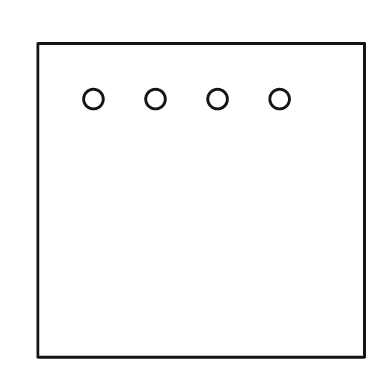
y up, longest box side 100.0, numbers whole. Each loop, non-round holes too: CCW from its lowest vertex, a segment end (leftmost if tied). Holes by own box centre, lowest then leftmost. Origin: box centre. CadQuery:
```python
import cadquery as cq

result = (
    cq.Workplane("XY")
    .moveTo(-50.0, -48.0)
    .lineTo(50.0, -48.0)
    .lineTo(50.0, 48.0)
    .lineTo(-50.0, 48.0)
    .close()
    .moveTo(-33.0, 31.0)
    .circle(3.0)
    .moveTo(-14.0, 31.0)
    .circle(3.0)
    .moveTo(5.0, 31.0)
    .circle(3.0)
    .moveTo(24.0, 31.0)
    .circle(3.0)
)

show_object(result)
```